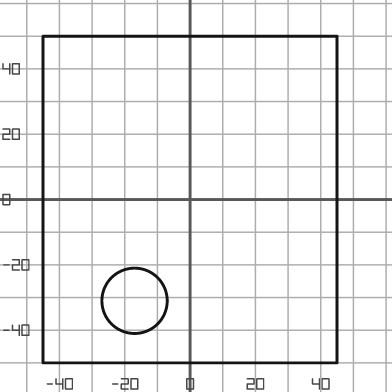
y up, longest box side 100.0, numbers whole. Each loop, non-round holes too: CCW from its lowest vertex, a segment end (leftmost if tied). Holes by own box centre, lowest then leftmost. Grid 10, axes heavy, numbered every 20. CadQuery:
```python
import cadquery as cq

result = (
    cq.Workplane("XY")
    .moveTo(-45.0, -50.0)
    .lineTo(45.0, -50.0)
    .lineTo(45.0, 50.0)
    .lineTo(-45.0, 50.0)
    .close()
    .moveTo(-17.0, -31.0)
    .circle(10.0)
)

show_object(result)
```